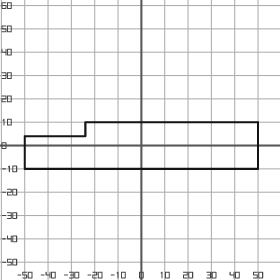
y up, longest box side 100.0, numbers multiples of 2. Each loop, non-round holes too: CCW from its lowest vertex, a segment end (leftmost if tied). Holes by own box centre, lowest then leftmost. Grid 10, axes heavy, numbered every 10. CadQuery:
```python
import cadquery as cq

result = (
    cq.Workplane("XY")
    .moveTo(-50.0, -10.0)
    .lineTo(50.0, -10.0)
    .lineTo(50.0, 10.0)
    .lineTo(-24.0, 10.0)
    .lineTo(-24.0, 4.0)
    .lineTo(-50.0, 4.0)
    .close()
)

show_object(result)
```